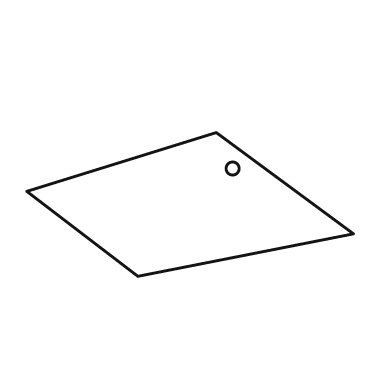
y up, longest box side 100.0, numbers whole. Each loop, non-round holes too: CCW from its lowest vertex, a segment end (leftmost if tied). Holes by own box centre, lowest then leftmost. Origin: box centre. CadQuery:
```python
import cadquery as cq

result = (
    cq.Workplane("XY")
    .moveTo(-16.0, -22.0)
    .lineTo(50.0, -9.0)
    .lineTo(8.0, 22.0)
    .lineTo(-50.0, 4.0)
    .close()
    .moveTo(13.0, 11.0)
    .circle(2.0)
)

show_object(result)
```